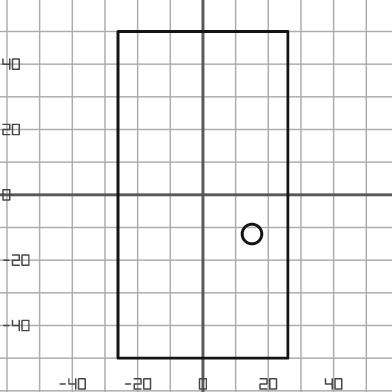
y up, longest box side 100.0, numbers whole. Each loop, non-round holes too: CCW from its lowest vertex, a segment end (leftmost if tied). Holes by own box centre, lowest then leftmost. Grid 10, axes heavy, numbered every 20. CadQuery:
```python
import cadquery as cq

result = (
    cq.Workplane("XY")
    .moveTo(-26.0, -50.0)
    .lineTo(26.0, -50.0)
    .lineTo(26.0, 50.0)
    .lineTo(-26.0, 50.0)
    .close()
    .moveTo(15.0, -12.0)
    .circle(3.0)
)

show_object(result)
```